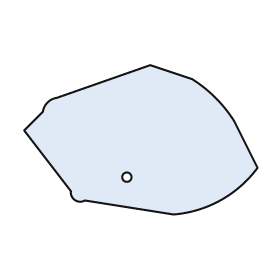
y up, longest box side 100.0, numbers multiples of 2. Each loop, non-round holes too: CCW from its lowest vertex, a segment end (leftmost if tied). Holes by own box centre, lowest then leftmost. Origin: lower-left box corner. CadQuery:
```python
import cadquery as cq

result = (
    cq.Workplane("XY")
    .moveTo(64.0, 0.0)
    .threePointArc((84.0, 6.0), (100.0, 20.0))
    .lineTo(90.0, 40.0)
    .threePointArc((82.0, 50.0), (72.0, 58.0))
    .lineTo(54.0, 64.0)
    .lineTo(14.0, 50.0)
    .threePointArc((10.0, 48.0), (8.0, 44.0))
    .lineTo(0.0, 36.0)
    .lineTo(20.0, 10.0)
    .threePointArc((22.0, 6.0), (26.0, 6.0))
    .close()
    .moveTo(44.0, 16.0)
    .circle(2.0)
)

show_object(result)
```